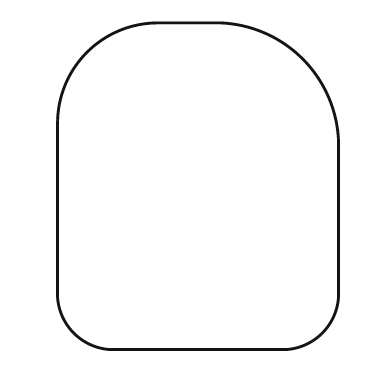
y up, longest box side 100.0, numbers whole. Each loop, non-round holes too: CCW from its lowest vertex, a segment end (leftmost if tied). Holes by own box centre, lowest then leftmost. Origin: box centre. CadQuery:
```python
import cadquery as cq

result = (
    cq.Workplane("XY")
    .moveTo(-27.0, -50.0)
    .lineTo(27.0, -50.0)
    .threePointArc((38.0, -45.0), (43.0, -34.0))
    .lineTo(43.0, 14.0)
    .threePointArc((32.0, 39.0), (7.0, 50.0))
    .lineTo(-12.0, 50.0)
    .threePointArc((-34.0, 41.0), (-43.0, 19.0))
    .lineTo(-43.0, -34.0)
    .threePointArc((-38.0, -45.0), (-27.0, -50.0))
    .close()
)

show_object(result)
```